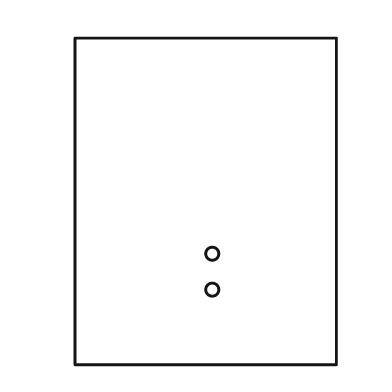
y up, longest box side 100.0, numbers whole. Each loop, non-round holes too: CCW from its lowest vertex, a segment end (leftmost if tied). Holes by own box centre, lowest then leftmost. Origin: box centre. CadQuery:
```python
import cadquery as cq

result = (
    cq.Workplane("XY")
    .moveTo(-40.0, -50.0)
    .lineTo(40.0, -50.0)
    .lineTo(40.0, 50.0)
    .lineTo(-40.0, 50.0)
    .close()
    .moveTo(2.0, -27.0)
    .circle(2.0)
    .moveTo(2.0, -16.0)
    .circle(2.0)
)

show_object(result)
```